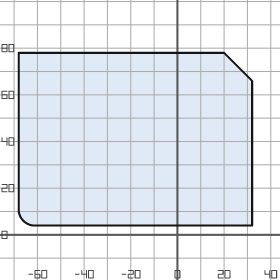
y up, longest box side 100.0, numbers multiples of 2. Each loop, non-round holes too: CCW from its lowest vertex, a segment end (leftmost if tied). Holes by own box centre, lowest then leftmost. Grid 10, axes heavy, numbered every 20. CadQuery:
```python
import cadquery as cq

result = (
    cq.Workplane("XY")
    .moveTo(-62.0, 4.0)
    .lineTo(32.0, 4.0)
    .lineTo(32.0, 66.0)
    .lineTo(20.0, 78.0)
    .lineTo(-68.0, 78.0)
    .lineTo(-68.0, 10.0)
    .threePointArc((-66.0, 6.0), (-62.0, 4.0))
    .close()
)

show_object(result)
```